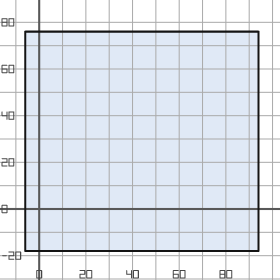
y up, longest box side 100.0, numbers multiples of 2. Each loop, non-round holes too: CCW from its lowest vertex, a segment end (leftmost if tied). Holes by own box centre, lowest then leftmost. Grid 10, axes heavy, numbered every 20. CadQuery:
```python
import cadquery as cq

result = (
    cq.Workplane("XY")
    .moveTo(-6.0, -18.0)
    .lineTo(94.0, -18.0)
    .lineTo(94.0, 76.0)
    .lineTo(-6.0, 76.0)
    .close()
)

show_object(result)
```